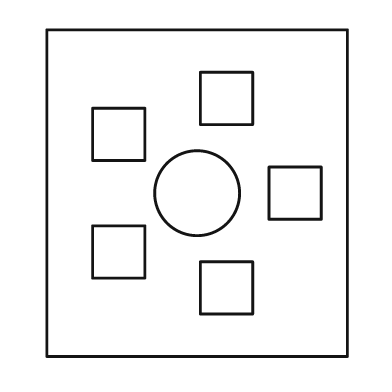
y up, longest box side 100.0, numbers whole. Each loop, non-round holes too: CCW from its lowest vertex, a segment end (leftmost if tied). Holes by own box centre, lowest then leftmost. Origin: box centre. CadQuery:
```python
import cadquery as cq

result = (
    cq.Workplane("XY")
    .moveTo(-46.0, -50.0)
    .lineTo(46.0, -50.0)
    .lineTo(46.0, 50.0)
    .lineTo(-46.0, 50.0)
    .close()
    .moveTo(1.0, -37.0)
    .lineTo(17.0, -37.0)
    .lineTo(17.0, -21.0)
    .lineTo(1.0, -21.0)
    .close()
    .moveTo(-32.0, -26.0)
    .lineTo(-16.0, -26.0)
    .lineTo(-16.0, -10.0)
    .lineTo(-32.0, -10.0)
    .close()
    .moveTo(0.0, 0.0)
    .circle(13.0)
    .moveTo(22.0, -8.0)
    .lineTo(38.0, -8.0)
    .lineTo(38.0, 8.0)
    .lineTo(22.0, 8.0)
    .close()
    .moveTo(-32.0, 10.0)
    .lineTo(-16.0, 10.0)
    .lineTo(-16.0, 26.0)
    .lineTo(-32.0, 26.0)
    .close()
    .moveTo(1.0, 21.0)
    .lineTo(17.0, 21.0)
    .lineTo(17.0, 37.0)
    .lineTo(1.0, 37.0)
    .close()
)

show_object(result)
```